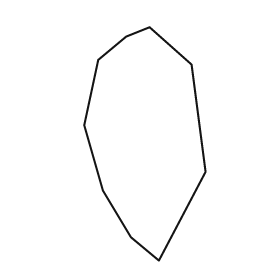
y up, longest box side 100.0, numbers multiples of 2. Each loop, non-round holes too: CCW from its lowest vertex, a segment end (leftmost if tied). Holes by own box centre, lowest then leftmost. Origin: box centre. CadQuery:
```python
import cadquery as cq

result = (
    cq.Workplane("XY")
    .moveTo(6.0, -50.0)
    .lineTo(26.0, -12.0)
    .lineTo(20.0, 34.0)
    .lineTo(2.0, 50.0)
    .lineTo(-8.0, 46.0)
    .lineTo(-20.0, 36.0)
    .lineTo(-26.0, 8.0)
    .lineTo(-18.0, -20.0)
    .lineTo(-6.0, -40.0)
    .close()
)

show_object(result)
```